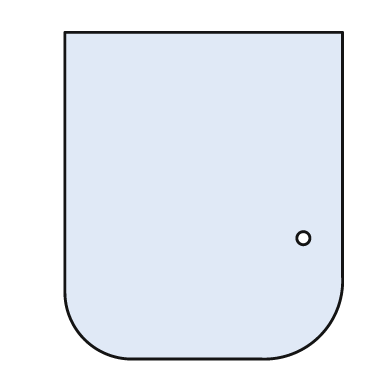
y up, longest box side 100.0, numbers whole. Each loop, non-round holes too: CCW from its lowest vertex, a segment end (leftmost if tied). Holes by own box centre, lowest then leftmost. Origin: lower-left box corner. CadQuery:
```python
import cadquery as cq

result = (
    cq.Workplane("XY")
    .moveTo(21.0, 0.0)
    .lineTo(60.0, 0.0)
    .threePointArc((78.0, 7.0), (85.0, 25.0))
    .lineTo(85.0, 100.0)
    .lineTo(0.0, 100.0)
    .lineTo(0.0, 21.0)
    .threePointArc((6.0, 6.0), (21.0, 0.0))
    .close()
    .moveTo(73.0, 37.0)
    .circle(2.0)
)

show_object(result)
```